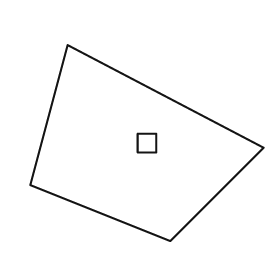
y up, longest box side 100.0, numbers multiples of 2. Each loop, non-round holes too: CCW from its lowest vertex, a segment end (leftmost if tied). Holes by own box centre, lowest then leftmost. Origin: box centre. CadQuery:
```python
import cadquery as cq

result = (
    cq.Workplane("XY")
    .moveTo(10.0, -42.0)
    .lineTo(50.0, -2.0)
    .lineTo(-34.0, 42.0)
    .lineTo(-50.0, -18.0)
    .close()
    .moveTo(-4.0, -4.0)
    .lineTo(4.0, -4.0)
    .lineTo(4.0, 4.0)
    .lineTo(-4.0, 4.0)
    .close()
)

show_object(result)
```